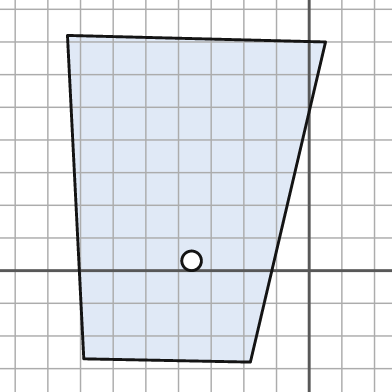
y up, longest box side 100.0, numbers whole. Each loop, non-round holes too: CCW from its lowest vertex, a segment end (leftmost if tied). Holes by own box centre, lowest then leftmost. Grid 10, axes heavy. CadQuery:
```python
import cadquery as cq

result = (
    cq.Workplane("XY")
    .moveTo(-18.0, -28.0)
    .lineTo(5.0, 70.0)
    .lineTo(-74.0, 72.0)
    .lineTo(-69.0, -27.0)
    .close()
    .moveTo(-36.0, 3.0)
    .circle(3.0)
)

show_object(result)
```